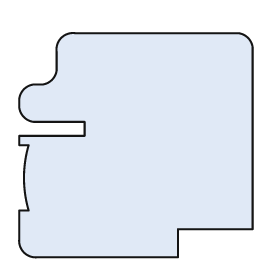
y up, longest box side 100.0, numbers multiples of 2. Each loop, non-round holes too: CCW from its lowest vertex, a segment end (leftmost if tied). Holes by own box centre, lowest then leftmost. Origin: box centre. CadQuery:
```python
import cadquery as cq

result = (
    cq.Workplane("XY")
    .moveTo(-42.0, -48.0)
    .lineTo(18.0, -48.0)
    .lineTo(18.0, -36.0)
    .lineTo(50.0, -36.0)
    .lineTo(50.0, 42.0)
    .threePointArc((48.0, 46.0), (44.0, 48.0))
    .lineTo(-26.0, 48.0)
    .threePointArc((-32.0, 46.0), (-34.0, 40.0))
    .lineTo(-34.0, 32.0)
    .threePointArc((-36.0, 28.0), (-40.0, 26.0))
    .lineTo(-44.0, 26.0)
    .threePointArc((-48.0, 24.0), (-50.0, 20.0))
    .lineTo(-50.0, 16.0)
    .threePointArc((-48.0, 12.0), (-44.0, 10.0))
    .lineTo(-22.0, 10.0)
    .lineTo(-22.0, 4.0)
    .lineTo(-50.0, 4.0)
    .lineTo(-50.0, 0.0)
    .lineTo(-46.0, 0.0)
    .threePointArc((-48.0, -14.0), (-46.0, -28.0))
    .lineTo(-50.0, -28.0)
    .lineTo(-50.0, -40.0)
    .threePointArc((-48.0, -46.0), (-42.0, -48.0))
    .close()
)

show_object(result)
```